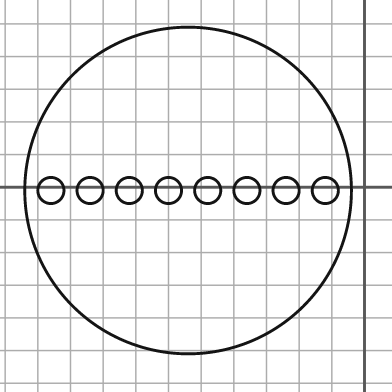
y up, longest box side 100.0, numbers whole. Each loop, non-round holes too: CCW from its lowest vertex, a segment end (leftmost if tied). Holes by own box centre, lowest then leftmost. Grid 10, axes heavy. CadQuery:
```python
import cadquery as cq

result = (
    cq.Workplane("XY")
    .moveTo(-54.0, -1.0)
    .circle(50.0)
    .moveTo(-96.0, -1.0)
    .circle(4.0)
    .moveTo(-84.0, -1.0)
    .circle(4.0)
    .moveTo(-72.0, -1.0)
    .circle(4.0)
    .moveTo(-60.0, -1.0)
    .circle(4.0)
    .moveTo(-48.0, -1.0)
    .circle(4.0)
    .moveTo(-36.0, -1.0)
    .circle(4.0)
    .moveTo(-24.0, -1.0)
    .circle(4.0)
    .moveTo(-12.0, -1.0)
    .circle(4.0)
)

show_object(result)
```